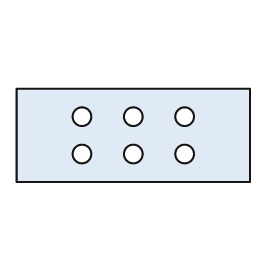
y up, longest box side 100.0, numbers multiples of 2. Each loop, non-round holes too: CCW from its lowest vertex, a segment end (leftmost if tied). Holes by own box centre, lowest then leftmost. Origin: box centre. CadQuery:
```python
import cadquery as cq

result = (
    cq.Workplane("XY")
    .moveTo(-50.0, -20.0)
    .lineTo(50.0, -20.0)
    .lineTo(50.0, 20.0)
    .lineTo(-50.0, 20.0)
    .close()
    .moveTo(-22.0, -8.0)
    .circle(4.0)
    .moveTo(0.0, -8.0)
    .circle(4.0)
    .moveTo(22.0, -8.0)
    .circle(4.0)
    .moveTo(-22.0, 8.0)
    .circle(4.0)
    .moveTo(0.0, 8.0)
    .circle(4.0)
    .moveTo(22.0, 8.0)
    .circle(4.0)
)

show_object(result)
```